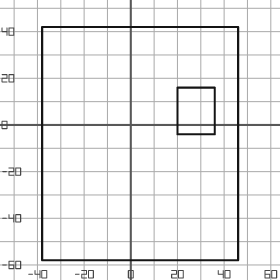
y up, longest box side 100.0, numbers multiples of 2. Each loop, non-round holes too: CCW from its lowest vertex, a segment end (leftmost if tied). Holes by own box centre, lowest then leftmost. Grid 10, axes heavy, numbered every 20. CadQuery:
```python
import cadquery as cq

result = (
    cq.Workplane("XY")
    .moveTo(-38.0, -58.0)
    .lineTo(46.0, -58.0)
    .lineTo(46.0, 42.0)
    .lineTo(-38.0, 42.0)
    .close()
    .moveTo(20.0, -4.0)
    .lineTo(36.0, -4.0)
    .lineTo(36.0, 16.0)
    .lineTo(20.0, 16.0)
    .close()
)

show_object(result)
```